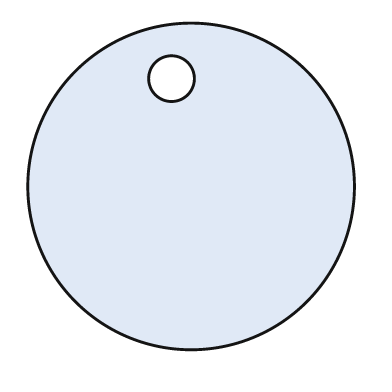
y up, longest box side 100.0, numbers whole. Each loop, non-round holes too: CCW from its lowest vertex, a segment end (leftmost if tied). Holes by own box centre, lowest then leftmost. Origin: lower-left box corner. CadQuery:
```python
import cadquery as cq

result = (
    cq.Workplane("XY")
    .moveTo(50.0, 50.0)
    .circle(50.0)
    .moveTo(44.0, 83.0)
    .circle(7.0)
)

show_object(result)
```